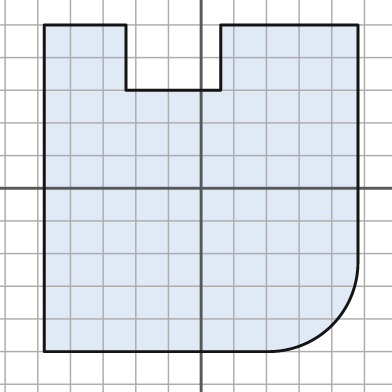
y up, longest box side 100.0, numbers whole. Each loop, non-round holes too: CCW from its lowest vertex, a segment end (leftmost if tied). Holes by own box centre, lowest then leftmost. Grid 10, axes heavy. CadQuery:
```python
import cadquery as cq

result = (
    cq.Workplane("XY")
    .moveTo(-48.0, -50.0)
    .lineTo(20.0, -50.0)
    .threePointArc((40.0, -42.0), (48.0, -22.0))
    .lineTo(48.0, 50.0)
    .lineTo(6.0, 50.0)
    .lineTo(6.0, 30.0)
    .lineTo(-23.0, 30.0)
    .lineTo(-23.0, 50.0)
    .lineTo(-48.0, 50.0)
    .close()
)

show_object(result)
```